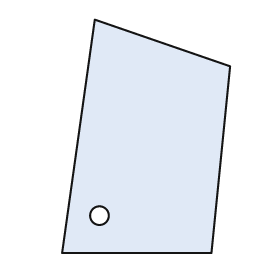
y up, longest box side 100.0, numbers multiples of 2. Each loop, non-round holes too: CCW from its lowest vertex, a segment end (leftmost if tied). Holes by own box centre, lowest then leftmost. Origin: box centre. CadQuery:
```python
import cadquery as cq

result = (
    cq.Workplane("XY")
    .moveTo(-36.0, -50.0)
    .lineTo(28.0, -50.0)
    .lineTo(36.0, 30.0)
    .lineTo(-22.0, 50.0)
    .close()
    .moveTo(-20.0, -34.0)
    .circle(4.0)
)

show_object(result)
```